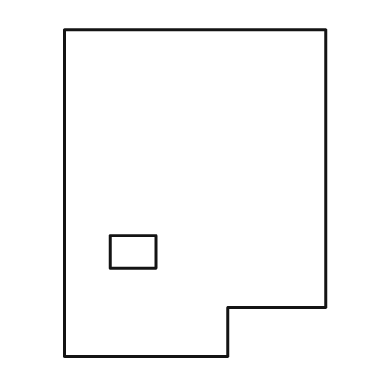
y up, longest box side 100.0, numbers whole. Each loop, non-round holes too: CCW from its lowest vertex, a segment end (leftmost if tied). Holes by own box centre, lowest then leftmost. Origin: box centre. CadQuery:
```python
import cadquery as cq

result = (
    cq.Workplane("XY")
    .moveTo(-40.0, -50.0)
    .lineTo(10.0, -50.0)
    .lineTo(10.0, -35.0)
    .lineTo(40.0, -35.0)
    .lineTo(40.0, 50.0)
    .lineTo(-40.0, 50.0)
    .close()
    .moveTo(-26.0, -23.0)
    .lineTo(-12.0, -23.0)
    .lineTo(-12.0, -13.0)
    .lineTo(-26.0, -13.0)
    .close()
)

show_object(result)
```